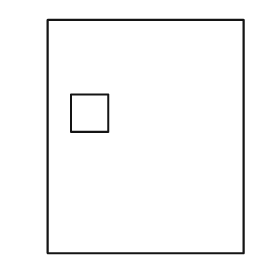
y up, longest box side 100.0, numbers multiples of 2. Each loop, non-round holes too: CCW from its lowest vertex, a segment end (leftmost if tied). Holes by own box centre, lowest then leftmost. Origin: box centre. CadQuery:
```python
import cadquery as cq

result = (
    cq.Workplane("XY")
    .moveTo(-42.0, -50.0)
    .lineTo(42.0, -50.0)
    .lineTo(42.0, 50.0)
    .lineTo(-42.0, 50.0)
    .close()
    .moveTo(-32.0, 2.0)
    .lineTo(-16.0, 2.0)
    .lineTo(-16.0, 18.0)
    .lineTo(-32.0, 18.0)
    .close()
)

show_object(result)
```